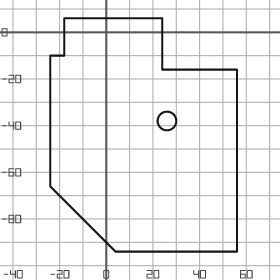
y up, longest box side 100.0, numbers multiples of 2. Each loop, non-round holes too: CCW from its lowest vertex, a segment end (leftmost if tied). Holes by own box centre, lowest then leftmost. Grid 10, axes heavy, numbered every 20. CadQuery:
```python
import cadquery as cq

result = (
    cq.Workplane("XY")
    .moveTo(4.0, -94.0)
    .lineTo(56.0, -94.0)
    .lineTo(56.0, -16.0)
    .lineTo(24.0, -16.0)
    .lineTo(24.0, 6.0)
    .lineTo(-18.0, 6.0)
    .lineTo(-18.0, -10.0)
    .lineTo(-24.0, -10.0)
    .lineTo(-24.0, -66.0)
    .close()
    .moveTo(26.0, -38.0)
    .circle(4.0)
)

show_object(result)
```